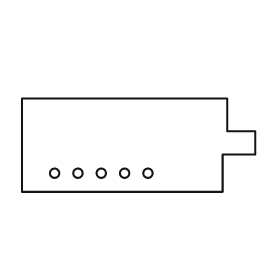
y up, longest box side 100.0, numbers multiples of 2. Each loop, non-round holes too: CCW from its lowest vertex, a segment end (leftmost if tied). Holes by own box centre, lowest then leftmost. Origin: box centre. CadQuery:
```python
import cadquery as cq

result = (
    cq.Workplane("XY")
    .moveTo(-50.0, -20.0)
    .lineTo(36.0, -20.0)
    .lineTo(36.0, -4.0)
    .lineTo(50.0, -4.0)
    .lineTo(50.0, 6.0)
    .lineTo(38.0, 6.0)
    .lineTo(38.0, 20.0)
    .lineTo(-50.0, 20.0)
    .close()
    .moveTo(-36.0, -12.0)
    .circle(2.0)
    .moveTo(-26.0, -12.0)
    .circle(2.0)
    .moveTo(-16.0, -12.0)
    .circle(2.0)
    .moveTo(-6.0, -12.0)
    .circle(2.0)
    .moveTo(4.0, -12.0)
    .circle(2.0)
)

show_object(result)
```